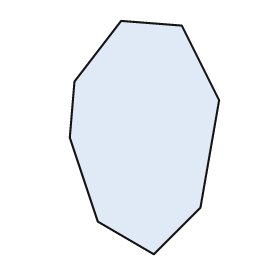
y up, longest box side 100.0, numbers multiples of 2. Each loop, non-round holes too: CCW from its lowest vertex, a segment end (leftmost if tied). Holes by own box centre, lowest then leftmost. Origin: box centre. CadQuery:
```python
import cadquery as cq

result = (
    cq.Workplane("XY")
    .moveTo(4.0, -50.0)
    .lineTo(24.0, -30.0)
    .lineTo(32.0, 16.0)
    .lineTo(16.0, 48.0)
    .lineTo(-10.0, 50.0)
    .lineTo(-30.0, 24.0)
    .lineTo(-32.0, 0.0)
    .lineTo(-20.0, -36.0)
    .close()
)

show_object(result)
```